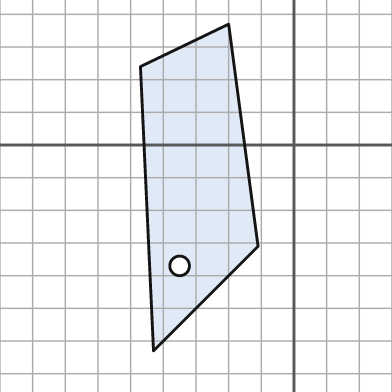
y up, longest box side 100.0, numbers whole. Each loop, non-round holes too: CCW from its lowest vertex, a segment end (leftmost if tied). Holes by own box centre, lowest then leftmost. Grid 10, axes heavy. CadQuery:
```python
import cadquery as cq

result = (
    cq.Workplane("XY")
    .moveTo(-43.0, -63.0)
    .lineTo(-11.0, -31.0)
    .lineTo(-20.0, 37.0)
    .lineTo(-47.0, 24.0)
    .close()
    .moveTo(-35.0, -37.0)
    .circle(3.0)
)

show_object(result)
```